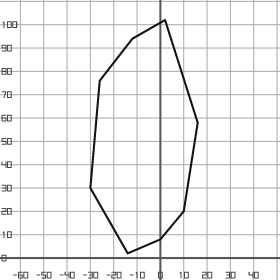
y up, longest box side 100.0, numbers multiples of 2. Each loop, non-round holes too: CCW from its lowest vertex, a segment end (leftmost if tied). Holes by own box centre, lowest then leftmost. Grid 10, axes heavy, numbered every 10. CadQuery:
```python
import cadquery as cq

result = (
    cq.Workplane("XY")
    .moveTo(-14.0, 2.0)
    .lineTo(0.0, 8.0)
    .lineTo(10.0, 20.0)
    .lineTo(16.0, 58.0)
    .lineTo(2.0, 102.0)
    .lineTo(-12.0, 94.0)
    .lineTo(-26.0, 76.0)
    .lineTo(-30.0, 30.0)
    .close()
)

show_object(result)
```